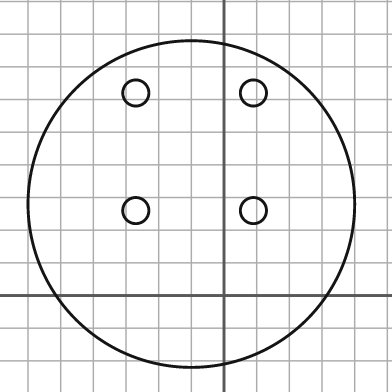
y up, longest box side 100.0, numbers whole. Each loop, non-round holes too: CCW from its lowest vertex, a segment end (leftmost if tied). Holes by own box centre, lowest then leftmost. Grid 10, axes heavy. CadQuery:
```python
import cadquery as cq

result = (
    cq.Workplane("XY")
    .moveTo(-10.0, 28.0)
    .circle(50.0)
    .moveTo(-27.0, 26.0)
    .circle(4.0)
    .moveTo(9.0, 26.0)
    .circle(4.0)
    .moveTo(-27.0, 62.0)
    .circle(4.0)
    .moveTo(9.0, 62.0)
    .circle(4.0)
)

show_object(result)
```